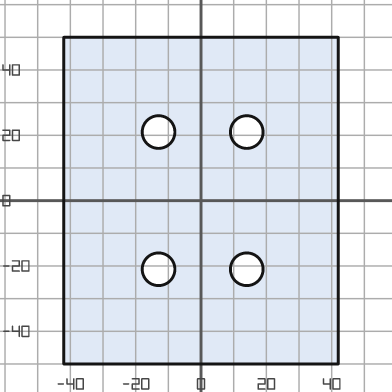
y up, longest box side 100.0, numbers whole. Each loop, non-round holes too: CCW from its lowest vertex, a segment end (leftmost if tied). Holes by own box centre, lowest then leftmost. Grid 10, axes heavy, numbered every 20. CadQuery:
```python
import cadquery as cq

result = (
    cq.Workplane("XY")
    .moveTo(-42.0, -50.0)
    .lineTo(42.0, -50.0)
    .lineTo(42.0, 50.0)
    .lineTo(-42.0, 50.0)
    .close()
    .moveTo(-13.0, -21.0)
    .circle(5.0)
    .moveTo(14.0, -21.0)
    .circle(5.0)
    .moveTo(-13.0, 21.0)
    .circle(5.0)
    .moveTo(14.0, 21.0)
    .circle(5.0)
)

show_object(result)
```